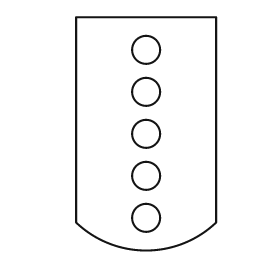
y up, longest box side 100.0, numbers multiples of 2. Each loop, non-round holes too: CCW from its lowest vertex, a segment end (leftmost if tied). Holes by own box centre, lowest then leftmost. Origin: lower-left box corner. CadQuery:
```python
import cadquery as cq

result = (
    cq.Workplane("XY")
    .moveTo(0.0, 12.0)
    .threePointArc((30.0, 0.0), (60.0, 12.0))
    .lineTo(60.0, 100.0)
    .lineTo(0.0, 100.0)
    .close()
    .moveTo(30.0, 14.0)
    .circle(6.0)
    .moveTo(30.0, 32.0)
    .circle(6.0)
    .moveTo(30.0, 50.0)
    .circle(6.0)
    .moveTo(30.0, 68.0)
    .circle(6.0)
    .moveTo(30.0, 86.0)
    .circle(6.0)
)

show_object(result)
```